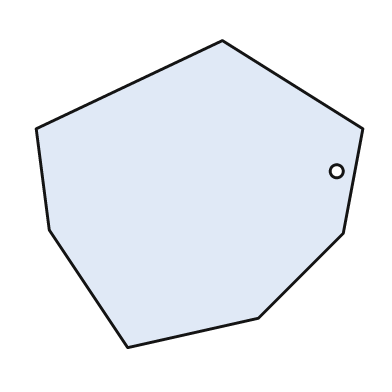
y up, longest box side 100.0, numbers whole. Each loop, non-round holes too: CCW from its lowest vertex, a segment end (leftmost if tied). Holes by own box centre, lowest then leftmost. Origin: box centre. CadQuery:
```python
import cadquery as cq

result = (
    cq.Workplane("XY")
    .moveTo(-22.0, -47.0)
    .lineTo(18.0, -38.0)
    .lineTo(44.0, -12.0)
    .lineTo(50.0, 20.0)
    .lineTo(7.0, 47.0)
    .lineTo(-50.0, 20.0)
    .lineTo(-46.0, -11.0)
    .close()
    .moveTo(42.0, 7.0)
    .circle(2.0)
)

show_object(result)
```